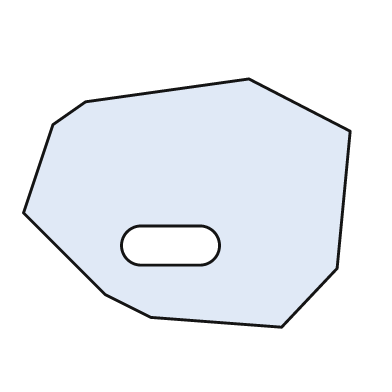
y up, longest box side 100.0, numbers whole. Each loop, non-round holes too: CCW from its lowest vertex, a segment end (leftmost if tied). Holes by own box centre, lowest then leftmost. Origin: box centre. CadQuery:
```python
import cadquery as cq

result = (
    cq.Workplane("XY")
    .moveTo(29.0, -38.0)
    .lineTo(46.0, -20.0)
    .lineTo(50.0, 22.0)
    .lineTo(19.0, 38.0)
    .lineTo(-31.0, 31.0)
    .lineTo(-41.0, 24.0)
    .lineTo(-50.0, -3.0)
    .lineTo(-25.0, -28.0)
    .lineTo(-11.0, -35.0)
    .close()
    .moveTo(-14.0, -19.0)
    .lineTo(4.0, -19.0)
    .threePointArc((10.0, -13.0), (4.0, -7.0))
    .lineTo(-14.0, -7.0)
    .threePointArc((-20.0, -13.0), (-14.0, -19.0))
    .close()
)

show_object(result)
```